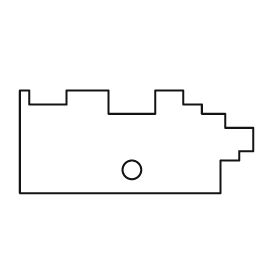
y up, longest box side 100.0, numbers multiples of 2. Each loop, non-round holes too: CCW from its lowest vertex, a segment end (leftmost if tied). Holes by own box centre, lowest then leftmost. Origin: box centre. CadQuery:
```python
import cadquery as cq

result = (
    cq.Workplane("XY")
    .moveTo(-50.0, -22.0)
    .lineTo(36.0, -22.0)
    .lineTo(36.0, -8.0)
    .lineTo(44.0, -8.0)
    .lineTo(44.0, -4.0)
    .lineTo(50.0, -4.0)
    .lineTo(50.0, 6.0)
    .lineTo(38.0, 6.0)
    .lineTo(38.0, 12.0)
    .lineTo(28.0, 12.0)
    .lineTo(28.0, 16.0)
    .lineTo(20.0, 16.0)
    .lineTo(20.0, 22.0)
    .lineTo(8.0, 22.0)
    .lineTo(8.0, 12.0)
    .lineTo(-12.0, 12.0)
    .lineTo(-12.0, 22.0)
    .lineTo(-30.0, 22.0)
    .lineTo(-30.0, 16.0)
    .lineTo(-46.0, 16.0)
    .lineTo(-46.0, 22.0)
    .lineTo(-50.0, 22.0)
    .close()
    .moveTo(-2.0, -12.0)
    .circle(4.0)
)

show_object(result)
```